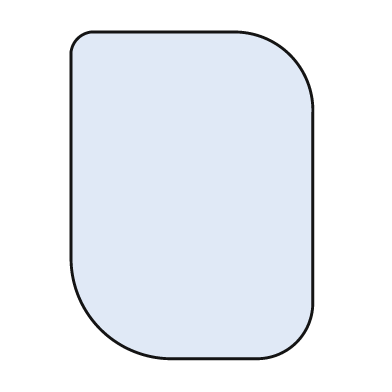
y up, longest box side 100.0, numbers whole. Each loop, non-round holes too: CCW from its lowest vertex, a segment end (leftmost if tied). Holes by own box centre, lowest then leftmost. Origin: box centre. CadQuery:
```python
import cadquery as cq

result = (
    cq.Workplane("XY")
    .moveTo(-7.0, -50.0)
    .lineTo(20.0, -50.0)
    .threePointArc((32.0, -45.0), (37.0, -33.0))
    .lineTo(37.0, 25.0)
    .threePointArc((30.0, 43.0), (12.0, 50.0))
    .lineTo(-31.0, 50.0)
    .threePointArc((-35.0, 48.0), (-37.0, 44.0))
    .lineTo(-37.0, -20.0)
    .threePointArc((-28.0, -41.0), (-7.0, -50.0))
    .close()
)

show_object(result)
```